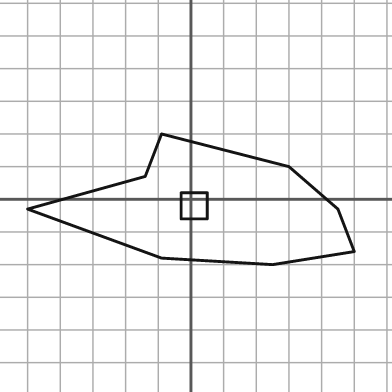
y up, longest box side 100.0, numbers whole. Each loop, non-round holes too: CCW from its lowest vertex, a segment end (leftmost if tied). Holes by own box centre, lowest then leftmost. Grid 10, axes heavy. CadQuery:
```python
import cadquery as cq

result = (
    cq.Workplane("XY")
    .moveTo(25.0, -20.0)
    .lineTo(50.0, -16.0)
    .lineTo(45.0, -3.0)
    .lineTo(30.0, 10.0)
    .lineTo(-9.0, 20.0)
    .lineTo(-14.0, 7.0)
    .lineTo(-50.0, -3.0)
    .lineTo(-9.0, -18.0)
    .close()
    .moveTo(-3.0, -6.0)
    .lineTo(5.0, -6.0)
    .lineTo(5.0, 2.0)
    .lineTo(-3.0, 2.0)
    .close()
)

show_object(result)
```